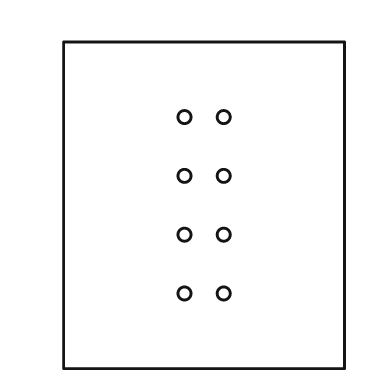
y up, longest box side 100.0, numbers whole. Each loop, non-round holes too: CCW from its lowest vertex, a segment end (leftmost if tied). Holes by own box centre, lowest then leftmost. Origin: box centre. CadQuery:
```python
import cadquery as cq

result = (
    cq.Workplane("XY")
    .moveTo(-43.0, -50.0)
    .lineTo(43.0, -50.0)
    .lineTo(43.0, 50.0)
    .lineTo(-43.0, 50.0)
    .close()
    .moveTo(-6.0, -27.0)
    .circle(2.0)
    .moveTo(6.0, -27.0)
    .circle(2.0)
    .moveTo(-6.0, -9.0)
    .circle(2.0)
    .moveTo(6.0, -9.0)
    .circle(2.0)
    .moveTo(-6.0, 9.0)
    .circle(2.0)
    .moveTo(6.0, 9.0)
    .circle(2.0)
    .moveTo(-6.0, 27.0)
    .circle(2.0)
    .moveTo(6.0, 27.0)
    .circle(2.0)
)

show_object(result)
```